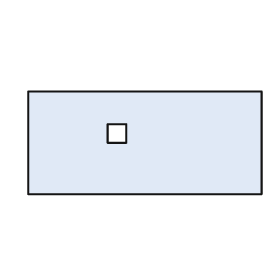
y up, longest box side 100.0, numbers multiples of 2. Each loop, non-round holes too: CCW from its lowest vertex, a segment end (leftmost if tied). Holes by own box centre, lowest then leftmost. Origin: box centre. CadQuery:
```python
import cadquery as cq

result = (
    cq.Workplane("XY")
    .moveTo(-50.0, -22.0)
    .lineTo(50.0, -22.0)
    .lineTo(50.0, 22.0)
    .lineTo(-50.0, 22.0)
    .close()
    .moveTo(-16.0, 0.0)
    .lineTo(-8.0, 0.0)
    .lineTo(-8.0, 8.0)
    .lineTo(-16.0, 8.0)
    .close()
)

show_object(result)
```